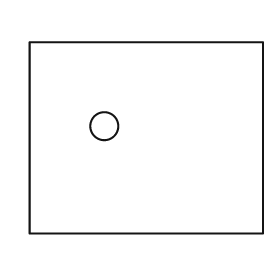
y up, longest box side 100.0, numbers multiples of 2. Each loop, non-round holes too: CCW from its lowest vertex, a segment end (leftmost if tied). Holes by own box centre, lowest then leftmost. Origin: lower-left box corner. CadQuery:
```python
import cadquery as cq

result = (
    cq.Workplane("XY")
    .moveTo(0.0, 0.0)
    .lineTo(100.0, 0.0)
    .lineTo(100.0, 82.0)
    .lineTo(0.0, 82.0)
    .close()
    .moveTo(32.0, 46.0)
    .circle(6.0)
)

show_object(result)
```